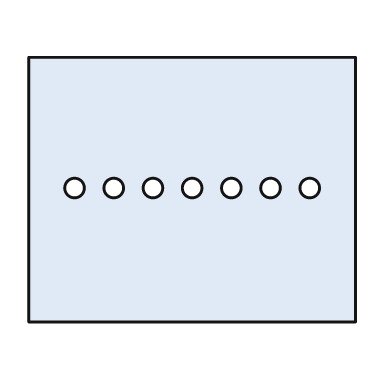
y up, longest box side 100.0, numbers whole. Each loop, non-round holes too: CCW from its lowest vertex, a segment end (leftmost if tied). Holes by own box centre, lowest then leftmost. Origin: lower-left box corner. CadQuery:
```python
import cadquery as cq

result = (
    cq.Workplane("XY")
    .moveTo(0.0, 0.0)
    .lineTo(100.0, 0.0)
    .lineTo(100.0, 81.0)
    .lineTo(0.0, 81.0)
    .close()
    .moveTo(14.0, 41.0)
    .circle(3.0)
    .moveTo(26.0, 41.0)
    .circle(3.0)
    .moveTo(38.0, 41.0)
    .circle(3.0)
    .moveTo(50.0, 41.0)
    .circle(3.0)
    .moveTo(62.0, 41.0)
    .circle(3.0)
    .moveTo(74.0, 41.0)
    .circle(3.0)
    .moveTo(86.0, 41.0)
    .circle(3.0)
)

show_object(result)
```